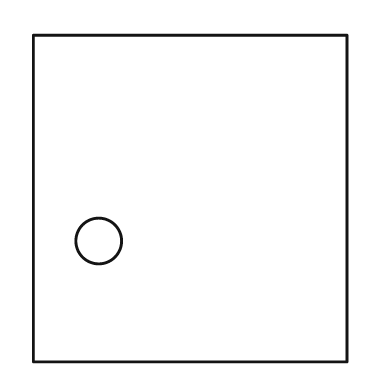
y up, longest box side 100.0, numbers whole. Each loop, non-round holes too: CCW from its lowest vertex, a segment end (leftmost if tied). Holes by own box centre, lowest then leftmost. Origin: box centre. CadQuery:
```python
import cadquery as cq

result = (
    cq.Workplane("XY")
    .moveTo(-48.0, -50.0)
    .lineTo(48.0, -50.0)
    .lineTo(48.0, 50.0)
    .lineTo(-48.0, 50.0)
    .close()
    .moveTo(-28.0, -13.0)
    .circle(7.0)
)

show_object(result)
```